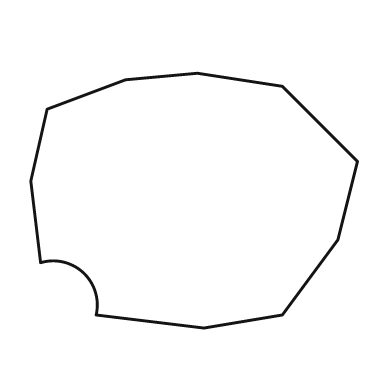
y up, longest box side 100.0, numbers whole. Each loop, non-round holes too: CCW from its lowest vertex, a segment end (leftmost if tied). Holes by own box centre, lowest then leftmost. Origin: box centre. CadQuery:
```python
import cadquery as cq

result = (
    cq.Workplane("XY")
    .moveTo(3.0, -39.0)
    .lineTo(27.0, -35.0)
    .lineTo(44.0, -12.0)
    .lineTo(50.0, 12.0)
    .lineTo(27.0, 35.0)
    .lineTo(1.0, 39.0)
    .lineTo(-21.0, 37.0)
    .lineTo(-45.0, 28.0)
    .lineTo(-50.0, 6.0)
    .lineTo(-47.0, -19.0)
    .threePointArc((-34.0, -22.0), (-30.0, -35.0))
    .close()
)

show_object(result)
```